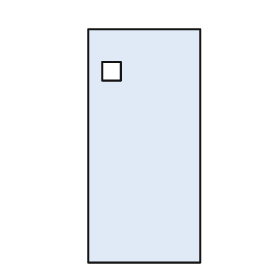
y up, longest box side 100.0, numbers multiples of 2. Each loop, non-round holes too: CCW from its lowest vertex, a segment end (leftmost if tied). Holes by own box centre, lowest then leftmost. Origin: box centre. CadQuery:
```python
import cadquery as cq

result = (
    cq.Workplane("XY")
    .moveTo(-24.0, -50.0)
    .lineTo(24.0, -50.0)
    .lineTo(24.0, 50.0)
    .lineTo(-24.0, 50.0)
    .close()
    .moveTo(-18.0, 28.0)
    .lineTo(-10.0, 28.0)
    .lineTo(-10.0, 36.0)
    .lineTo(-18.0, 36.0)
    .close()
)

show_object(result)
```